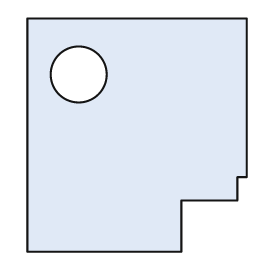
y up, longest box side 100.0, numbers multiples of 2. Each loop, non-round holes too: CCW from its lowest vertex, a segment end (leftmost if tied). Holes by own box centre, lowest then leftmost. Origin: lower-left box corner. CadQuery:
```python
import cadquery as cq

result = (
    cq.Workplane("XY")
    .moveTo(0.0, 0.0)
    .lineTo(66.0, 0.0)
    .lineTo(66.0, 22.0)
    .lineTo(90.0, 22.0)
    .lineTo(90.0, 32.0)
    .lineTo(94.0, 32.0)
    .lineTo(94.0, 100.0)
    .lineTo(0.0, 100.0)
    .close()
    .moveTo(22.0, 76.0)
    .circle(12.0)
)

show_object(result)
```